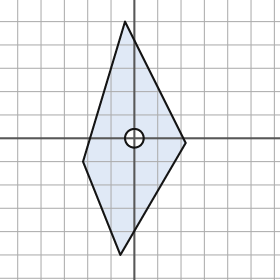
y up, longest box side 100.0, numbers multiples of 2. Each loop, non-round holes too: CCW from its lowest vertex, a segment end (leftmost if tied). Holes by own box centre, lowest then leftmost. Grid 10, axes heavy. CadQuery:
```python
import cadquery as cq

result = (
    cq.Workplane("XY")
    .moveTo(-6.0, -50.0)
    .lineTo(22.0, -2.0)
    .lineTo(-4.0, 50.0)
    .lineTo(-22.0, -10.0)
    .close()
    .moveTo(0.0, 0.0)
    .circle(4.0)
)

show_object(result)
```